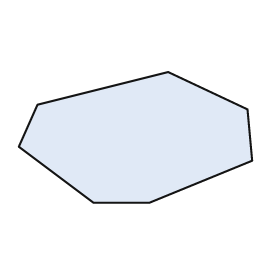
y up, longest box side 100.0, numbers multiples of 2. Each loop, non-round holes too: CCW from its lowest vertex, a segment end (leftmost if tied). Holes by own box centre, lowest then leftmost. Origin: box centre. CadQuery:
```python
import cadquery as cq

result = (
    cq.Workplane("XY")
    .moveTo(-18.0, -28.0)
    .lineTo(6.0, -28.0)
    .lineTo(50.0, -10.0)
    .lineTo(48.0, 12.0)
    .lineTo(14.0, 28.0)
    .lineTo(-42.0, 14.0)
    .lineTo(-50.0, -4.0)
    .close()
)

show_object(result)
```